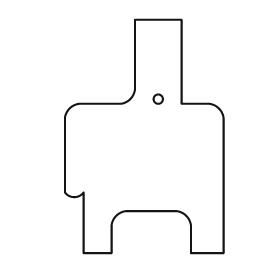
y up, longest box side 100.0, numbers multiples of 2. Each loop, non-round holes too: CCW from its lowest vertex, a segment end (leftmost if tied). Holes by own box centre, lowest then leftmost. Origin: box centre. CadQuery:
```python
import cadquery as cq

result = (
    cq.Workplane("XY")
    .moveTo(-26.0, -50.0)
    .lineTo(-14.0, -50.0)
    .lineTo(-14.0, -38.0)
    .threePointArc((-12.0, -34.0), (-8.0, -32.0))
    .lineTo(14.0, -32.0)
    .threePointArc((18.0, -34.0), (20.0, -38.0))
    .lineTo(20.0, -50.0)
    .lineTo(34.0, -50.0)
    .lineTo(34.0, 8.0)
    .threePointArc((32.0, 12.0), (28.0, 14.0))
    .lineTo(16.0, 14.0)
    .lineTo(16.0, 50.0)
    .lineTo(-4.0, 50.0)
    .lineTo(-4.0, 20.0)
    .threePointArc((-6.0, 16.0), (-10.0, 14.0))
    .lineTo(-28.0, 14.0)
    .threePointArc((-32.0, 12.0), (-34.0, 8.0))
    .lineTo(-34.0, -24.0)
    .threePointArc((-30.0, -26.0), (-26.0, -24.0))
    .close()
    .moveTo(6.0, 16.0)
    .circle(2.0)
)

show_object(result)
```